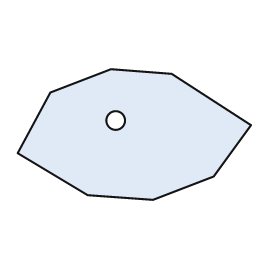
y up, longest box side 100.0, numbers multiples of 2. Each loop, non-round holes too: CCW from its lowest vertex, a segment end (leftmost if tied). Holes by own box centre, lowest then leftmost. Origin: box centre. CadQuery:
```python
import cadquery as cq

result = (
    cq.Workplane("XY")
    .moveTo(8.0, -28.0)
    .lineTo(34.0, -18.0)
    .lineTo(50.0, 4.0)
    .lineTo(16.0, 26.0)
    .lineTo(-10.0, 28.0)
    .lineTo(-36.0, 18.0)
    .lineTo(-50.0, -8.0)
    .lineTo(-20.0, -26.0)
    .close()
    .moveTo(-8.0, 6.0)
    .circle(4.0)
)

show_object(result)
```